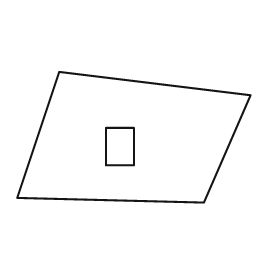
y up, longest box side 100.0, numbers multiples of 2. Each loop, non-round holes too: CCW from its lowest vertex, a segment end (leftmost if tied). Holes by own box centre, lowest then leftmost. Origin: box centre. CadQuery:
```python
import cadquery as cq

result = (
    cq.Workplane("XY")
    .moveTo(30.0, -28.0)
    .lineTo(50.0, 18.0)
    .lineTo(-32.0, 28.0)
    .lineTo(-50.0, -26.0)
    .close()
    .moveTo(-12.0, -12.0)
    .lineTo(0.0, -12.0)
    .lineTo(0.0, 4.0)
    .lineTo(-12.0, 4.0)
    .close()
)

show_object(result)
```